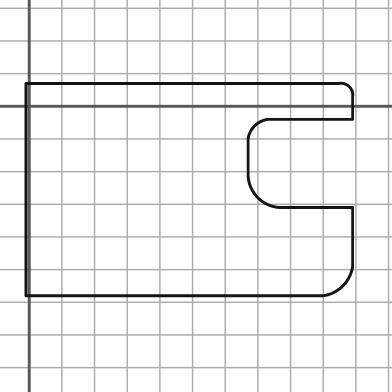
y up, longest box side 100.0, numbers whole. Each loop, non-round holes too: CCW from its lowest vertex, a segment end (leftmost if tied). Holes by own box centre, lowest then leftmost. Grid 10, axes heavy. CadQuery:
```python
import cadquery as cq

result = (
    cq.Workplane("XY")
    .moveTo(-1.0, -58.0)
    .lineTo(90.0, -58.0)
    .threePointArc((96.0, -55.0), (99.0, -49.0))
    .lineTo(99.0, -31.0)
    .lineTo(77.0, -31.0)
    .threePointArc((70.0, -28.0), (67.0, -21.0))
    .lineTo(67.0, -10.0)
    .threePointArc((69.0, -6.0), (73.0, -4.0))
    .lineTo(99.0, -4.0)
    .lineTo(99.0, 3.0)
    .threePointArc((98.0, 6.0), (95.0, 7.0))
    .lineTo(-1.0, 7.0)
    .close()
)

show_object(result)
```